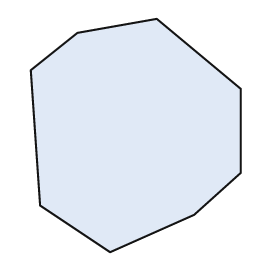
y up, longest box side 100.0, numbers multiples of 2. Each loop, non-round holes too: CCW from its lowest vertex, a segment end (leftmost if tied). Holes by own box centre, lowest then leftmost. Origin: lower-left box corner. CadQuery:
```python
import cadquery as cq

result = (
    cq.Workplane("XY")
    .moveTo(34.0, 0.0)
    .lineTo(70.0, 16.0)
    .lineTo(90.0, 34.0)
    .lineTo(90.0, 70.0)
    .lineTo(54.0, 100.0)
    .lineTo(20.0, 94.0)
    .lineTo(0.0, 78.0)
    .lineTo(4.0, 20.0)
    .close()
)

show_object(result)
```